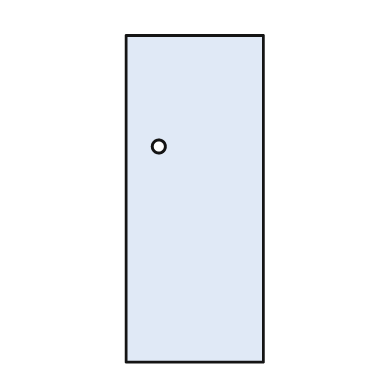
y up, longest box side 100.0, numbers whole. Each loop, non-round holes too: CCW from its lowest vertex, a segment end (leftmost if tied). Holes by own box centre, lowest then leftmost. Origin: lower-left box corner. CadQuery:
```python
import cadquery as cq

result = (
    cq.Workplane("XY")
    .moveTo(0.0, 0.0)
    .lineTo(42.0, 0.0)
    .lineTo(42.0, 100.0)
    .lineTo(0.0, 100.0)
    .close()
    .moveTo(10.0, 66.0)
    .circle(2.0)
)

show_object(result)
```